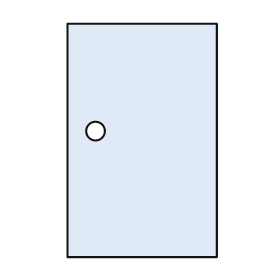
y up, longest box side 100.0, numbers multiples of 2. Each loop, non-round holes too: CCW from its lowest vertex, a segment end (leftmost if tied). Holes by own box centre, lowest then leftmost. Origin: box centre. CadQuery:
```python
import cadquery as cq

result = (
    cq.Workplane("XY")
    .moveTo(-32.0, -50.0)
    .lineTo(32.0, -50.0)
    .lineTo(32.0, 50.0)
    .lineTo(-32.0, 50.0)
    .close()
    .moveTo(-20.0, 4.0)
    .circle(4.0)
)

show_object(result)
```